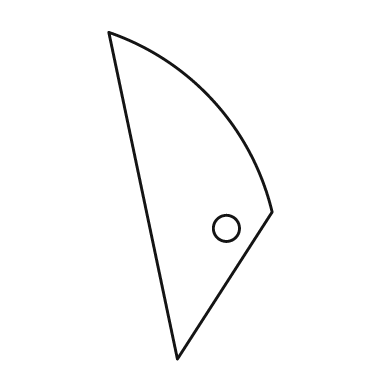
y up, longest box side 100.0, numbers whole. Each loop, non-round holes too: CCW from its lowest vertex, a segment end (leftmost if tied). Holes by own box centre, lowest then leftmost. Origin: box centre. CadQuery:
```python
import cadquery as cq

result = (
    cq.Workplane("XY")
    .moveTo(-4.0, -50.0)
    .lineTo(25.0, -5.0)
    .threePointArc((7.0, 29.0), (-25.0, 50.0))
    .close()
    .moveTo(11.0, -10.0)
    .circle(4.0)
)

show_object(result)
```